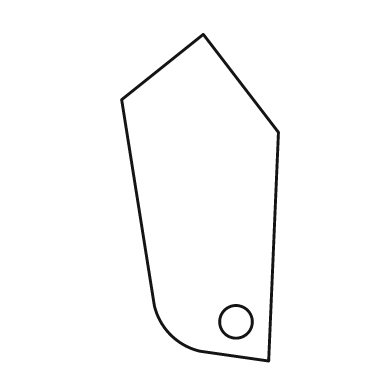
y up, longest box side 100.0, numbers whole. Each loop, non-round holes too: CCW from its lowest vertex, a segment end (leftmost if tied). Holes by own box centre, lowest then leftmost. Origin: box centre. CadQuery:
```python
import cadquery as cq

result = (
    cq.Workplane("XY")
    .moveTo(21.0, -50.0)
    .lineTo(24.0, 20.0)
    .lineTo(1.0, 50.0)
    .lineTo(-24.0, 30.0)
    .lineTo(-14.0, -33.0)
    .threePointArc((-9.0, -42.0), (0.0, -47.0))
    .close()
    .moveTo(11.0, -38.0)
    .circle(5.0)
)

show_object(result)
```